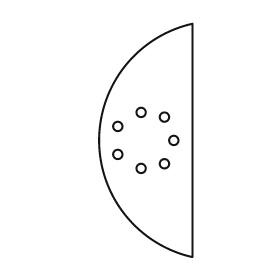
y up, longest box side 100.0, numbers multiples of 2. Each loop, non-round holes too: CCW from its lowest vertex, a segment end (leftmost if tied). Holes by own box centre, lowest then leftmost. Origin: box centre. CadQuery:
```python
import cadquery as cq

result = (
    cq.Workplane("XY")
    .moveTo(20.0, -50.0)
    .lineTo(20.0, 50.0)
    .threePointArc((-20.0, 0.0), (20.0, -50.0))
    .close()
    .moveTo(-2.0, -12.0)
    .circle(2.0)
    .moveTo(8.0, -10.0)
    .circle(2.0)
    .moveTo(-12.0, -6.0)
    .circle(2.0)
    .moveTo(12.0, 0.0)
    .circle(2.0)
    .moveTo(-12.0, 6.0)
    .circle(2.0)
    .moveTo(8.0, 10.0)
    .circle(2.0)
    .moveTo(-2.0, 12.0)
    .circle(2.0)
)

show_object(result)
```